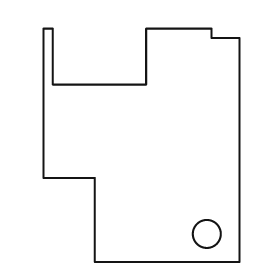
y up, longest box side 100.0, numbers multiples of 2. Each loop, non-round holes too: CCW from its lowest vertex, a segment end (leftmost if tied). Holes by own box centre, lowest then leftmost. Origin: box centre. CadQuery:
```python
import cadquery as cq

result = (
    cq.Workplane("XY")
    .moveTo(-20.0, -50.0)
    .lineTo(42.0, -50.0)
    .lineTo(42.0, 46.0)
    .lineTo(30.0, 46.0)
    .lineTo(30.0, 50.0)
    .lineTo(2.0, 50.0)
    .lineTo(2.0, 26.0)
    .lineTo(-38.0, 26.0)
    .lineTo(-38.0, 50.0)
    .lineTo(-42.0, 50.0)
    .lineTo(-42.0, -14.0)
    .lineTo(-20.0, -14.0)
    .close()
    .moveTo(28.0, -38.0)
    .circle(6.0)
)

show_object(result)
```